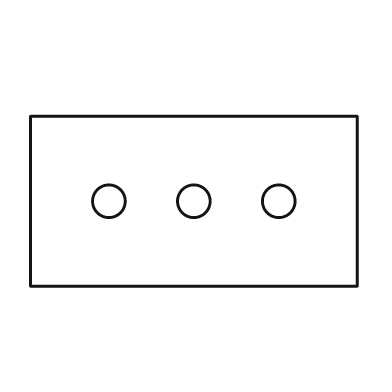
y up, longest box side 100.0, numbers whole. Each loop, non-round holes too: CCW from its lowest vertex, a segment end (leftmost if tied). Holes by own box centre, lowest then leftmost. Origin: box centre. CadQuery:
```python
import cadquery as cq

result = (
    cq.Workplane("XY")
    .moveTo(-50.0, -26.0)
    .lineTo(50.0, -26.0)
    .lineTo(50.0, 26.0)
    .lineTo(-50.0, 26.0)
    .close()
    .moveTo(-26.0, 0.0)
    .circle(5.0)
    .moveTo(0.0, 0.0)
    .circle(5.0)
    .moveTo(26.0, 0.0)
    .circle(5.0)
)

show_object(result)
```